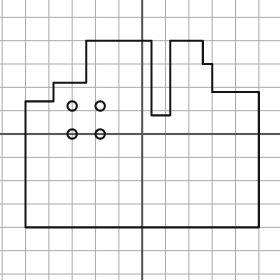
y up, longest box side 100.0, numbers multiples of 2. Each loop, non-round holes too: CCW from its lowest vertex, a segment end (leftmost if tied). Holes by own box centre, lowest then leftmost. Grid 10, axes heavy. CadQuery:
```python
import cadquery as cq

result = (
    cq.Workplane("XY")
    .moveTo(-50.0, -40.0)
    .lineTo(50.0, -40.0)
    .lineTo(50.0, 18.0)
    .lineTo(30.0, 18.0)
    .lineTo(30.0, 30.0)
    .lineTo(26.0, 30.0)
    .lineTo(26.0, 40.0)
    .lineTo(12.0, 40.0)
    .lineTo(12.0, 8.0)
    .lineTo(4.0, 8.0)
    .lineTo(4.0, 40.0)
    .lineTo(-24.0, 40.0)
    .lineTo(-24.0, 22.0)
    .lineTo(-38.0, 22.0)
    .lineTo(-38.0, 14.0)
    .lineTo(-50.0, 14.0)
    .close()
    .moveTo(-30.0, 0.0)
    .circle(2.0)
    .moveTo(-18.0, 0.0)
    .circle(2.0)
    .moveTo(-30.0, 12.0)
    .circle(2.0)
    .moveTo(-18.0, 12.0)
    .circle(2.0)
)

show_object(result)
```